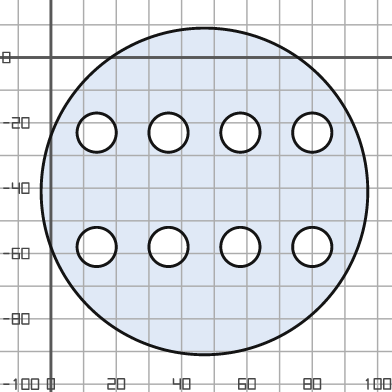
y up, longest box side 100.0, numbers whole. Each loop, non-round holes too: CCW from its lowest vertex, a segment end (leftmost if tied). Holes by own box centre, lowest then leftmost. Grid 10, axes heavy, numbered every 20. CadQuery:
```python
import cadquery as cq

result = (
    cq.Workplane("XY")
    .moveTo(47.0, -41.0)
    .circle(50.0)
    .moveTo(14.0, -58.0)
    .circle(6.0)
    .moveTo(36.0, -58.0)
    .circle(6.0)
    .moveTo(58.0, -58.0)
    .circle(6.0)
    .moveTo(80.0, -58.0)
    .circle(6.0)
    .moveTo(14.0, -23.0)
    .circle(6.0)
    .moveTo(36.0, -23.0)
    .circle(6.0)
    .moveTo(58.0, -23.0)
    .circle(6.0)
    .moveTo(80.0, -23.0)
    .circle(6.0)
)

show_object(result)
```